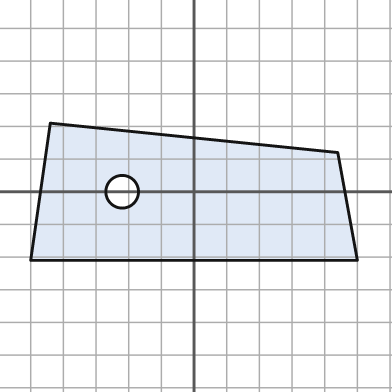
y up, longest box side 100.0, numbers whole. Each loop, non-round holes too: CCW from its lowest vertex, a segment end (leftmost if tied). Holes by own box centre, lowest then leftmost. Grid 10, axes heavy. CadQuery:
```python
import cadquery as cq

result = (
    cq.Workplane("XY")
    .moveTo(-50.0, -21.0)
    .lineTo(50.0, -21.0)
    .lineTo(44.0, 12.0)
    .lineTo(-44.0, 21.0)
    .close()
    .moveTo(-22.0, 0.0)
    .circle(5.0)
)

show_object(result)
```